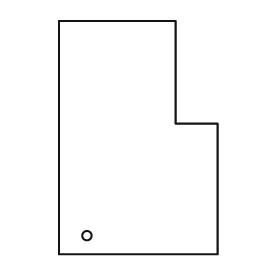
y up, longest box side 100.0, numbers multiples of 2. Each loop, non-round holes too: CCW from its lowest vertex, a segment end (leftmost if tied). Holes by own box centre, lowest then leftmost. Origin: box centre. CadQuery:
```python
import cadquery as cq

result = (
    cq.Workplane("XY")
    .moveTo(-34.0, -50.0)
    .lineTo(34.0, -50.0)
    .lineTo(34.0, 6.0)
    .lineTo(16.0, 6.0)
    .lineTo(16.0, 50.0)
    .lineTo(-34.0, 50.0)
    .close()
    .moveTo(-22.0, -42.0)
    .circle(2.0)
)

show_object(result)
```